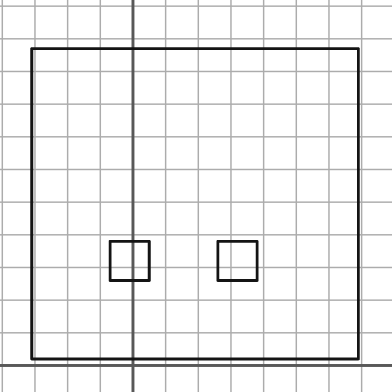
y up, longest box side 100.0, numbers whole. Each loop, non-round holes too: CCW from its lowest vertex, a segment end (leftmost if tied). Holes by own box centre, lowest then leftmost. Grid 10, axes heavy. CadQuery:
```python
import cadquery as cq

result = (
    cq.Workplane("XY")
    .moveTo(-31.0, 2.0)
    .lineTo(69.0, 2.0)
    .lineTo(69.0, 97.0)
    .lineTo(-31.0, 97.0)
    .close()
    .moveTo(-7.0, 26.0)
    .lineTo(5.0, 26.0)
    .lineTo(5.0, 38.0)
    .lineTo(-7.0, 38.0)
    .close()
    .moveTo(26.0, 26.0)
    .lineTo(38.0, 26.0)
    .lineTo(38.0, 38.0)
    .lineTo(26.0, 38.0)
    .close()
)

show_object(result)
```